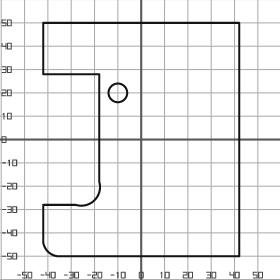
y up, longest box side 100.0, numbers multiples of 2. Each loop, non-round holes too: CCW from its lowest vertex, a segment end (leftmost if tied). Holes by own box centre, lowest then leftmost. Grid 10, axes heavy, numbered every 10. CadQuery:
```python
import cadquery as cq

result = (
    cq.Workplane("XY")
    .moveTo(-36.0, -50.0)
    .lineTo(42.0, -50.0)
    .lineTo(42.0, 50.0)
    .lineTo(-42.0, 50.0)
    .lineTo(-42.0, 28.0)
    .lineTo(-18.0, 28.0)
    .lineTo(-18.0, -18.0)
    .threePointArc((-20.0, -26.0), (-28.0, -28.0))
    .lineTo(-42.0, -28.0)
    .lineTo(-42.0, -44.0)
    .threePointArc((-40.0, -48.0), (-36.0, -50.0))
    .close()
    .moveTo(-10.0, 20.0)
    .circle(4.0)
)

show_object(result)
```